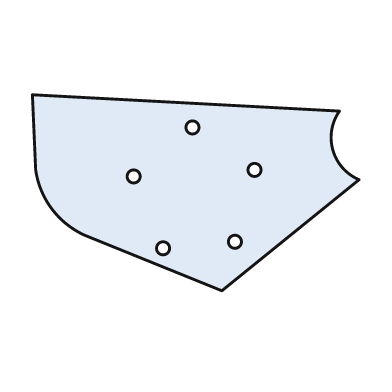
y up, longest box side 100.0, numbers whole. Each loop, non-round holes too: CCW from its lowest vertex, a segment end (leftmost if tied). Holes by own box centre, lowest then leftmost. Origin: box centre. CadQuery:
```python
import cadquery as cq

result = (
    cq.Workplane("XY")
    .moveTo(8.0, -30.0)
    .lineTo(50.0, 4.0)
    .threePointArc((42.0, 13.0), (44.0, 25.0))
    .lineTo(-50.0, 30.0)
    .lineTo(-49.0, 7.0)
    .threePointArc((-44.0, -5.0), (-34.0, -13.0))
    .close()
    .moveTo(-10.0, -17.0)
    .circle(2.0)
    .moveTo(12.0, -15.0)
    .circle(2.0)
    .moveTo(-19.0, 5.0)
    .circle(2.0)
    .moveTo(18.0, 7.0)
    .circle(2.0)
    .moveTo(-1.0, 20.0)
    .circle(2.0)
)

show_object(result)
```